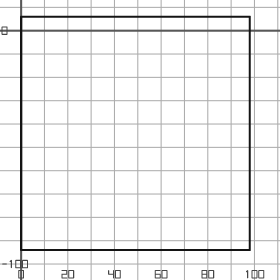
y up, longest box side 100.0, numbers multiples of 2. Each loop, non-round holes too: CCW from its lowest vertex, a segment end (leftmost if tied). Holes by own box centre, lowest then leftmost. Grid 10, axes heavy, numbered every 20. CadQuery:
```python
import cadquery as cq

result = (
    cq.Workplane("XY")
    .moveTo(0.0, -94.0)
    .lineTo(98.0, -94.0)
    .lineTo(98.0, 6.0)
    .lineTo(0.0, 6.0)
    .close()
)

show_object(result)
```